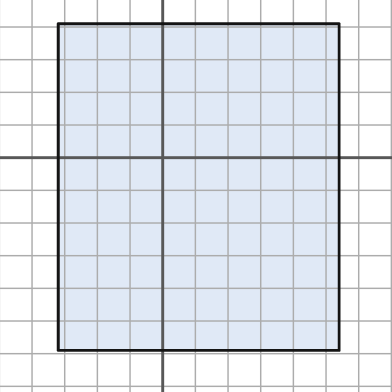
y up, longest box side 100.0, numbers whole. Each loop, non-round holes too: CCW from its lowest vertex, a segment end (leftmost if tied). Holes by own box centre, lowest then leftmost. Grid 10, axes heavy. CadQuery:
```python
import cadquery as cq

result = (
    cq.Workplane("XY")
    .moveTo(-32.0, -59.0)
    .lineTo(54.0, -59.0)
    .lineTo(54.0, 41.0)
    .lineTo(-32.0, 41.0)
    .close()
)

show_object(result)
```